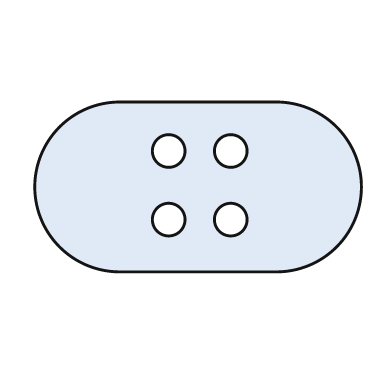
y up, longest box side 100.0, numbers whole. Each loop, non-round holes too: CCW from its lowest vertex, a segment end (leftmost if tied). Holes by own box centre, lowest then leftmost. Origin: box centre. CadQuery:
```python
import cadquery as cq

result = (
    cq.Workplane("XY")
    .moveTo(-24.0, -26.0)
    .lineTo(24.0, -26.0)
    .threePointArc((50.0, 0.0), (24.0, 26.0))
    .lineTo(-24.0, 26.0)
    .threePointArc((-50.0, 0.0), (-24.0, -26.0))
    .close()
    .moveTo(-9.0, -10.0)
    .circle(5.0)
    .moveTo(10.0, -10.0)
    .circle(5.0)
    .moveTo(-9.0, 11.0)
    .circle(5.0)
    .moveTo(10.0, 11.0)
    .circle(5.0)
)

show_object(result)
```